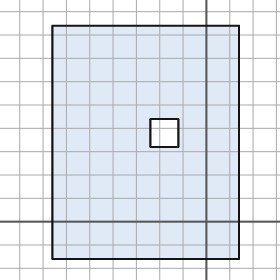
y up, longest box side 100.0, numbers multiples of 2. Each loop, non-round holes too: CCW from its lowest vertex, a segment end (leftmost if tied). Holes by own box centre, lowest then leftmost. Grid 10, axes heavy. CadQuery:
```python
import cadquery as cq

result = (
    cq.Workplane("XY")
    .moveTo(-66.0, -16.0)
    .lineTo(14.0, -16.0)
    .lineTo(14.0, 84.0)
    .lineTo(-66.0, 84.0)
    .close()
    .moveTo(-24.0, 32.0)
    .lineTo(-12.0, 32.0)
    .lineTo(-12.0, 44.0)
    .lineTo(-24.0, 44.0)
    .close()
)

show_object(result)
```